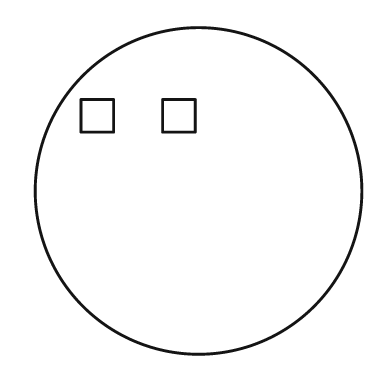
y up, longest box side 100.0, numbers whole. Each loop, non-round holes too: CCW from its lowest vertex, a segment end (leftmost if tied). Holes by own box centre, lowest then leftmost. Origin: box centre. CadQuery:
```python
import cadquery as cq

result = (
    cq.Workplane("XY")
    .moveTo(0.0, 0.0)
    .circle(50.0)
    .moveTo(-36.0, 18.0)
    .lineTo(-26.0, 18.0)
    .lineTo(-26.0, 28.0)
    .lineTo(-36.0, 28.0)
    .close()
    .moveTo(-11.0, 18.0)
    .lineTo(-1.0, 18.0)
    .lineTo(-1.0, 28.0)
    .lineTo(-11.0, 28.0)
    .close()
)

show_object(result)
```